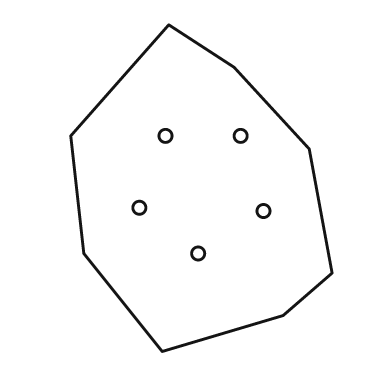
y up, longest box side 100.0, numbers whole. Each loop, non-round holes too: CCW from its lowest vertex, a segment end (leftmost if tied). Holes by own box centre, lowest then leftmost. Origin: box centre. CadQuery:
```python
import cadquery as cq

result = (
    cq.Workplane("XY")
    .moveTo(-12.0, -50.0)
    .lineTo(25.0, -39.0)
    .lineTo(40.0, -26.0)
    .lineTo(33.0, 12.0)
    .lineTo(10.0, 37.0)
    .lineTo(-10.0, 50.0)
    .lineTo(-40.0, 16.0)
    .lineTo(-36.0, -20.0)
    .close()
    .moveTo(-1.0, -20.0)
    .circle(2.0)
    .moveTo(19.0, -7.0)
    .circle(2.0)
    .moveTo(-19.0, -6.0)
    .circle(2.0)
    .moveTo(-11.0, 16.0)
    .circle(2.0)
    .moveTo(12.0, 16.0)
    .circle(2.0)
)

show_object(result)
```